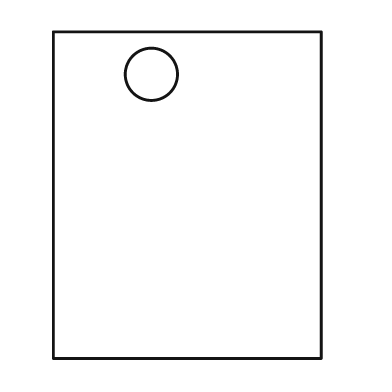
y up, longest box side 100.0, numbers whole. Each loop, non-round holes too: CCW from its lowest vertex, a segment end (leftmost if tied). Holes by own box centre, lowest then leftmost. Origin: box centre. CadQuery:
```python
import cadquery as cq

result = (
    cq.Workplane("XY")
    .moveTo(-41.0, -50.0)
    .lineTo(41.0, -50.0)
    .lineTo(41.0, 50.0)
    .lineTo(-41.0, 50.0)
    .close()
    .moveTo(-11.0, 37.0)
    .circle(8.0)
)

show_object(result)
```